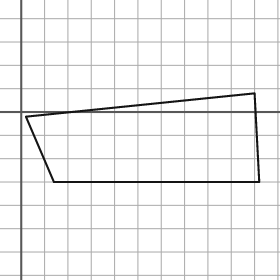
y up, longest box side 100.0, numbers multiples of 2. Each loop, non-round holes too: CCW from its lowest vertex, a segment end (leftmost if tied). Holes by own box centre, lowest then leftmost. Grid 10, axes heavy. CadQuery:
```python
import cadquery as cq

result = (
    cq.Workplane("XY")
    .moveTo(14.0, -30.0)
    .lineTo(102.0, -30.0)
    .lineTo(100.0, 8.0)
    .lineTo(2.0, -2.0)
    .close()
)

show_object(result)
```